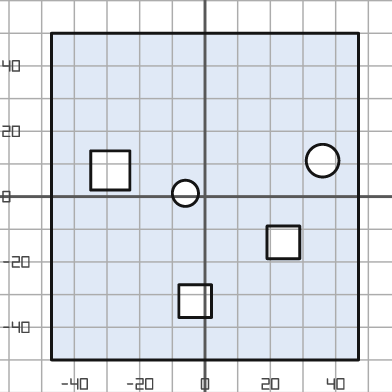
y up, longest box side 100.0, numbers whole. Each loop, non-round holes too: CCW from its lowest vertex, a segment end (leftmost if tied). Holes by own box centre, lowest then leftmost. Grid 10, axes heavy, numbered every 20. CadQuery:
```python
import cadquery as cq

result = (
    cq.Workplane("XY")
    .moveTo(-47.0, -50.0)
    .lineTo(47.0, -50.0)
    .lineTo(47.0, 50.0)
    .lineTo(-47.0, 50.0)
    .close()
    .moveTo(-8.0, -37.0)
    .lineTo(2.0, -37.0)
    .lineTo(2.0, -27.0)
    .lineTo(-8.0, -27.0)
    .close()
    .moveTo(19.0, -19.0)
    .lineTo(29.0, -19.0)
    .lineTo(29.0, -9.0)
    .lineTo(19.0, -9.0)
    .close()
    .moveTo(-6.0, 1.0)
    .circle(4.0)
    .moveTo(-35.0, 2.0)
    .lineTo(-23.0, 2.0)
    .lineTo(-23.0, 14.0)
    .lineTo(-35.0, 14.0)
    .close()
    .moveTo(36.0, 11.0)
    .circle(5.0)
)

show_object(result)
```